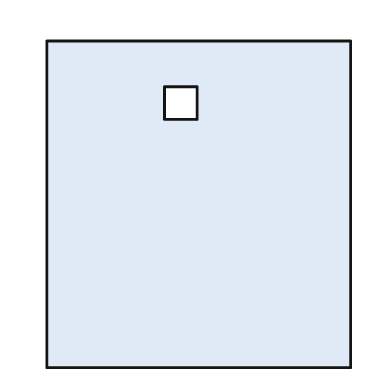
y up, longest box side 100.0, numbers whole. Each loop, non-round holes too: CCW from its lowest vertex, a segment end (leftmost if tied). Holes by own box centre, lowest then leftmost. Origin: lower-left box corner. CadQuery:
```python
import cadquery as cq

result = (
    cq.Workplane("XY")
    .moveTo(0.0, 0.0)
    .lineTo(93.0, 0.0)
    .lineTo(93.0, 100.0)
    .lineTo(0.0, 100.0)
    .close()
    .moveTo(36.0, 76.0)
    .lineTo(46.0, 76.0)
    .lineTo(46.0, 86.0)
    .lineTo(36.0, 86.0)
    .close()
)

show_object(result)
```